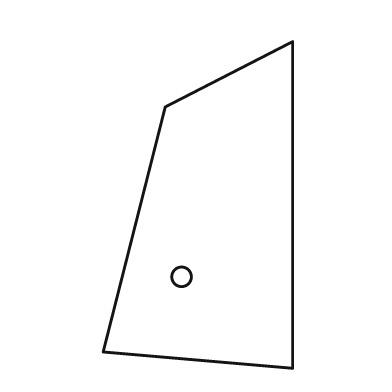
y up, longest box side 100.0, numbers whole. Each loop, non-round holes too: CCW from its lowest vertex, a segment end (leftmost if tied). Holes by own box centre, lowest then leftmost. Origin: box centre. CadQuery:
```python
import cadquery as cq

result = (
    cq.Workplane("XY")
    .moveTo(29.0, -50.0)
    .lineTo(29.0, 50.0)
    .lineTo(-10.0, 30.0)
    .lineTo(-29.0, -45.0)
    .close()
    .moveTo(-5.0, -22.0)
    .circle(3.0)
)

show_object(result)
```